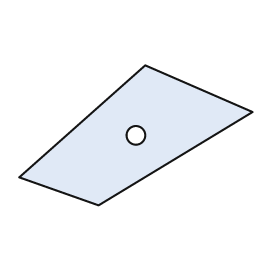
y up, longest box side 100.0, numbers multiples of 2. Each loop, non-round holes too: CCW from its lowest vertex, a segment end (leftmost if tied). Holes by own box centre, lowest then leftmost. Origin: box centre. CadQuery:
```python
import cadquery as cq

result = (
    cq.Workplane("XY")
    .moveTo(-16.0, -30.0)
    .lineTo(50.0, 10.0)
    .lineTo(4.0, 30.0)
    .lineTo(-50.0, -18.0)
    .close()
    .moveTo(0.0, 0.0)
    .circle(4.0)
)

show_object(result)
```